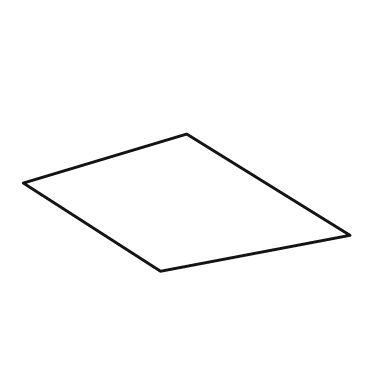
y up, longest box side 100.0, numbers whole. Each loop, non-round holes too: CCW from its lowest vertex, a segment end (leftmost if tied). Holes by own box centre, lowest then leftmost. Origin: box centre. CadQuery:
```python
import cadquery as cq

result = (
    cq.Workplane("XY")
    .moveTo(-8.0, -21.0)
    .lineTo(50.0, -10.0)
    .lineTo(0.0, 21.0)
    .lineTo(-50.0, 6.0)
    .close()
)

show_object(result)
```